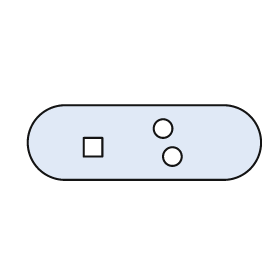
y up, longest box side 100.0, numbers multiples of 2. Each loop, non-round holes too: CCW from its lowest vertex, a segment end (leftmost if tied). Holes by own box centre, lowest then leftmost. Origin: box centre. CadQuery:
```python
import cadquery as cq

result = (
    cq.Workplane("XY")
    .moveTo(-34.0, -16.0)
    .lineTo(34.0, -16.0)
    .threePointArc((50.0, 0.0), (34.0, 16.0))
    .lineTo(-34.0, 16.0)
    .threePointArc((-50.0, 0.0), (-34.0, -16.0))
    .close()
    .moveTo(12.0, -6.0)
    .circle(4.0)
    .moveTo(-26.0, -6.0)
    .lineTo(-18.0, -6.0)
    .lineTo(-18.0, 2.0)
    .lineTo(-26.0, 2.0)
    .close()
    .moveTo(8.0, 6.0)
    .circle(4.0)
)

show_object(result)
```